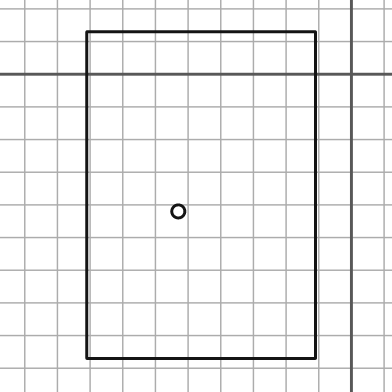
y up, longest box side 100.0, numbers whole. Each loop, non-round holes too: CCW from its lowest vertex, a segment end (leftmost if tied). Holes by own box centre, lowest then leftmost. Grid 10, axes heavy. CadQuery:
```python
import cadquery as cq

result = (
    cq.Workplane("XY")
    .moveTo(-81.0, -87.0)
    .lineTo(-11.0, -87.0)
    .lineTo(-11.0, 13.0)
    .lineTo(-81.0, 13.0)
    .close()
    .moveTo(-53.0, -42.0)
    .circle(2.0)
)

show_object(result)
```